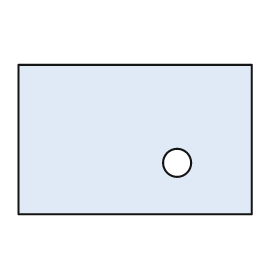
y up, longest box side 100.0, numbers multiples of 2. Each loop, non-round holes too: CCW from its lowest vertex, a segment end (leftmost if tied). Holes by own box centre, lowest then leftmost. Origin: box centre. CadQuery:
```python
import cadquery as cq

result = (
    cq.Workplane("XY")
    .moveTo(-50.0, -32.0)
    .lineTo(50.0, -32.0)
    .lineTo(50.0, 32.0)
    .lineTo(-50.0, 32.0)
    .close()
    .moveTo(18.0, -10.0)
    .circle(6.0)
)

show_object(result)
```